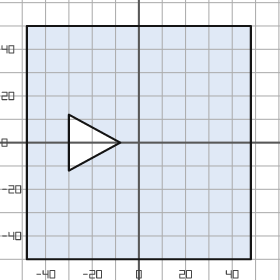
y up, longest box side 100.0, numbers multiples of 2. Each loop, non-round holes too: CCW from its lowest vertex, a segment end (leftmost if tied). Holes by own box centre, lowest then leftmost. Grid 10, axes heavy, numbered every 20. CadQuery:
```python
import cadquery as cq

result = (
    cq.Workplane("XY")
    .moveTo(-48.0, -50.0)
    .lineTo(48.0, -50.0)
    .lineTo(48.0, 50.0)
    .lineTo(-48.0, 50.0)
    .close()
    .moveTo(-30.0, -12.0)
    .lineTo(-8.0, 0.0)
    .lineTo(-30.0, 12.0)
    .close()
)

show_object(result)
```